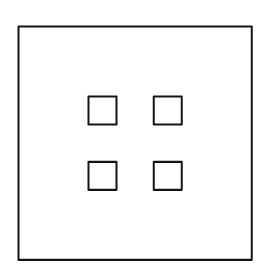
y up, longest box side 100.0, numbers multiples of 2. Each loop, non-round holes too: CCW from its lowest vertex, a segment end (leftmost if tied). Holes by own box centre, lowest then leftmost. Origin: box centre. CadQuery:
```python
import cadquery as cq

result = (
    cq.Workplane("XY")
    .moveTo(-50.0, -50.0)
    .lineTo(50.0, -50.0)
    .lineTo(50.0, 50.0)
    .lineTo(-50.0, 50.0)
    .close()
    .moveTo(-20.0, -20.0)
    .lineTo(-8.0, -20.0)
    .lineTo(-8.0, -8.0)
    .lineTo(-20.0, -8.0)
    .close()
    .moveTo(8.0, -20.0)
    .lineTo(20.0, -20.0)
    .lineTo(20.0, -8.0)
    .lineTo(8.0, -8.0)
    .close()
    .moveTo(-20.0, 8.0)
    .lineTo(-8.0, 8.0)
    .lineTo(-8.0, 20.0)
    .lineTo(-20.0, 20.0)
    .close()
    .moveTo(8.0, 8.0)
    .lineTo(20.0, 8.0)
    .lineTo(20.0, 20.0)
    .lineTo(8.0, 20.0)
    .close()
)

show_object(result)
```